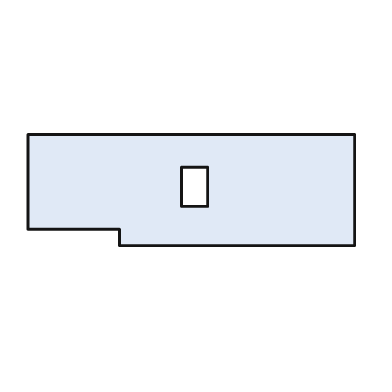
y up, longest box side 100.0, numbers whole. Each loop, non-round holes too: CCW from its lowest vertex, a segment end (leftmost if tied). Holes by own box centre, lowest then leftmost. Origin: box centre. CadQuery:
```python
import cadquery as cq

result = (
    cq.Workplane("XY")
    .moveTo(-22.0, -17.0)
    .lineTo(50.0, -17.0)
    .lineTo(50.0, 17.0)
    .lineTo(-50.0, 17.0)
    .lineTo(-50.0, -12.0)
    .lineTo(-22.0, -12.0)
    .close()
    .moveTo(-3.0, -5.0)
    .lineTo(5.0, -5.0)
    .lineTo(5.0, 7.0)
    .lineTo(-3.0, 7.0)
    .close()
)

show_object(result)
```